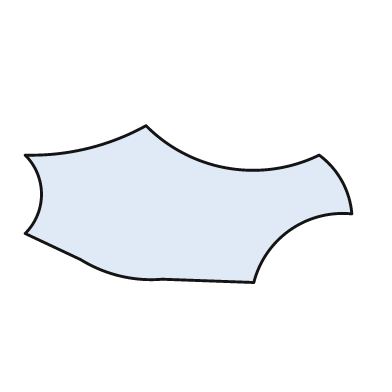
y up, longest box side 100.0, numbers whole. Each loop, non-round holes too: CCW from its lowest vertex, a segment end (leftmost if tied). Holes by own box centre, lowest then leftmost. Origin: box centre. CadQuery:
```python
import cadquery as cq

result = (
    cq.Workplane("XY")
    .moveTo(20.0, -24.0)
    .threePointArc((31.0, -8.0), (50.0, -3.0))
    .threePointArc((47.0, 7.0), (40.0, 15.0))
    .threePointArc((12.0, 11.0), (-13.0, 24.0))
    .threePointArc((-31.0, 17.0), (-50.0, 15.0))
    .threePointArc((-45.0, 3.0), (-50.0, -9.0))
    .lineTo(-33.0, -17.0)
    .threePointArc((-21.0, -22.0), (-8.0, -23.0))
    .close()
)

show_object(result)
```